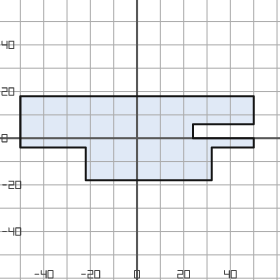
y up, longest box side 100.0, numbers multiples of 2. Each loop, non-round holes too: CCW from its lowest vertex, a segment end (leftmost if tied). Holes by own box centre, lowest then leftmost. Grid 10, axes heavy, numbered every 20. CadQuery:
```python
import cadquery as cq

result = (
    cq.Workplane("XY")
    .moveTo(-22.0, -18.0)
    .lineTo(32.0, -18.0)
    .lineTo(32.0, -4.0)
    .lineTo(50.0, -4.0)
    .lineTo(50.0, 0.0)
    .lineTo(24.0, 0.0)
    .lineTo(24.0, 6.0)
    .lineTo(50.0, 6.0)
    .lineTo(50.0, 18.0)
    .lineTo(-50.0, 18.0)
    .lineTo(-50.0, -4.0)
    .lineTo(-22.0, -4.0)
    .close()
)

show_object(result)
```